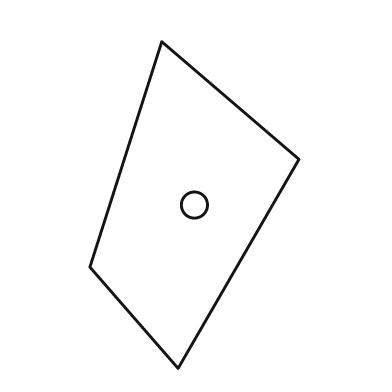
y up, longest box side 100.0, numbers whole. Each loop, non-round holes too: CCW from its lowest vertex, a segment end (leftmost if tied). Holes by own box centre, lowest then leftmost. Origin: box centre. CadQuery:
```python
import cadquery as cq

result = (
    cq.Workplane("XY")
    .moveTo(-5.0, -50.0)
    .lineTo(32.0, 14.0)
    .lineTo(-10.0, 50.0)
    .lineTo(-32.0, -19.0)
    .close()
    .moveTo(0.0, 0.0)
    .circle(4.0)
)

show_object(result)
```